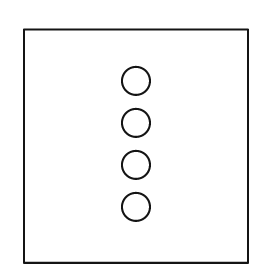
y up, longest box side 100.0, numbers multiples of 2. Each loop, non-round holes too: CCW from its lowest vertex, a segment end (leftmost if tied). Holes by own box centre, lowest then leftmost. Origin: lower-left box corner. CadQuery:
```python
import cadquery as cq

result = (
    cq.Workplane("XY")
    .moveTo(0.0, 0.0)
    .lineTo(96.0, 0.0)
    .lineTo(96.0, 100.0)
    .lineTo(0.0, 100.0)
    .close()
    .moveTo(48.0, 24.0)
    .circle(6.0)
    .moveTo(48.0, 42.0)
    .circle(6.0)
    .moveTo(48.0, 60.0)
    .circle(6.0)
    .moveTo(48.0, 78.0)
    .circle(6.0)
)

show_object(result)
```